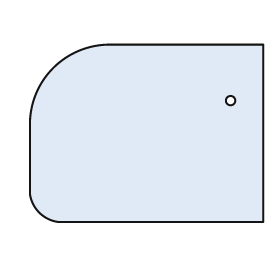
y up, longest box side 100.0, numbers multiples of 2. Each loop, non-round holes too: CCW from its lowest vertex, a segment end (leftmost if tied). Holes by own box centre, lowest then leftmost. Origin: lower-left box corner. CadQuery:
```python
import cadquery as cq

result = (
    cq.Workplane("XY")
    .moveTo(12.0, 0.0)
    .lineTo(100.0, 0.0)
    .lineTo(100.0, 76.0)
    .lineTo(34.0, 76.0)
    .threePointArc((10.0, 66.0), (0.0, 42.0))
    .lineTo(0.0, 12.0)
    .threePointArc((4.0, 4.0), (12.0, 0.0))
    .close()
    .moveTo(86.0, 52.0)
    .circle(2.0)
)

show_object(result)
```